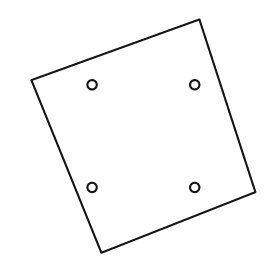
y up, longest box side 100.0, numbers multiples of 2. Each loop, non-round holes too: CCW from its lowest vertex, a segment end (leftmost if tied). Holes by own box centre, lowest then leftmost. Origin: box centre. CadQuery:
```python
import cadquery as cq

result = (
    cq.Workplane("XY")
    .moveTo(-18.0, -50.0)
    .lineTo(48.0, -24.0)
    .lineTo(24.0, 50.0)
    .lineTo(-48.0, 24.0)
    .close()
    .moveTo(-22.0, -22.0)
    .circle(2.0)
    .moveTo(22.0, -22.0)
    .circle(2.0)
    .moveTo(-22.0, 22.0)
    .circle(2.0)
    .moveTo(22.0, 22.0)
    .circle(2.0)
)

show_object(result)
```